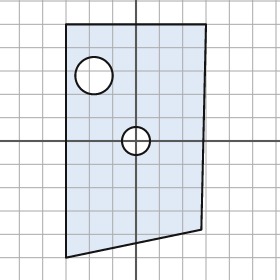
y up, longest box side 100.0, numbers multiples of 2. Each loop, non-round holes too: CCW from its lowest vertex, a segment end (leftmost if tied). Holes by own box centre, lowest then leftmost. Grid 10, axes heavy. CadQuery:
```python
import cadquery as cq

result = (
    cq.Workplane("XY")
    .moveTo(-30.0, -50.0)
    .lineTo(28.0, -38.0)
    .lineTo(30.0, 50.0)
    .lineTo(-30.0, 50.0)
    .close()
    .moveTo(0.0, 0.0)
    .circle(6.0)
    .moveTo(-18.0, 28.0)
    .circle(8.0)
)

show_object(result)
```